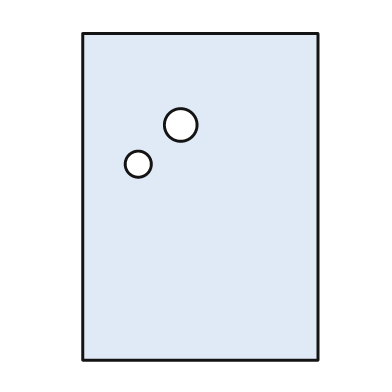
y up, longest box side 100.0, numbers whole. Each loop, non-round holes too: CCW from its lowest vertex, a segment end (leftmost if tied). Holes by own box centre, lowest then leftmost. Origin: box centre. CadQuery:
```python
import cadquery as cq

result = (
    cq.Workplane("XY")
    .moveTo(-36.0, -50.0)
    .lineTo(36.0, -50.0)
    .lineTo(36.0, 50.0)
    .lineTo(-36.0, 50.0)
    .close()
    .moveTo(-19.0, 10.0)
    .circle(4.0)
    .moveTo(-6.0, 22.0)
    .circle(5.0)
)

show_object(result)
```